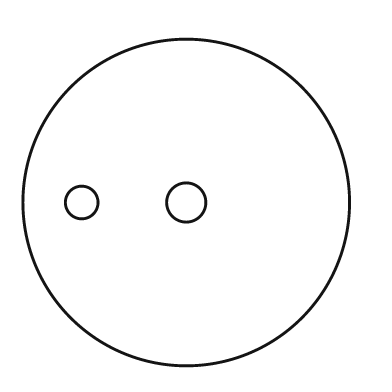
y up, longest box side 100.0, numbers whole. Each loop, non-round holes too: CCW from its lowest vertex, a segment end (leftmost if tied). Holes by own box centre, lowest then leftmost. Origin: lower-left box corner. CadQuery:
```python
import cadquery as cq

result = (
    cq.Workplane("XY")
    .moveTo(50.0, 50.0)
    .circle(50.0)
    .moveTo(18.0, 50.0)
    .circle(5.0)
    .moveTo(50.0, 50.0)
    .circle(6.0)
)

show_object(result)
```